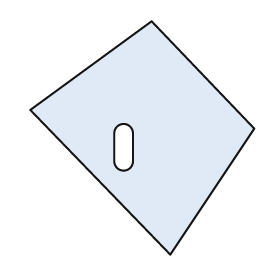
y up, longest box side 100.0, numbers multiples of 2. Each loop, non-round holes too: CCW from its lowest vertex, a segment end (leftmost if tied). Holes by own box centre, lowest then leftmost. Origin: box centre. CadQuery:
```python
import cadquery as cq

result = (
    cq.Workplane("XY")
    .moveTo(12.0, -50.0)
    .lineTo(48.0, 4.0)
    .lineTo(4.0, 50.0)
    .lineTo(-48.0, 12.0)
    .close()
    .moveTo(-12.0, -10.0)
    .threePointArc((-8.0, -14.0), (-4.0, -10.0))
    .lineTo(-4.0, 2.0)
    .threePointArc((-8.0, 6.0), (-12.0, 2.0))
    .close()
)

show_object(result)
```